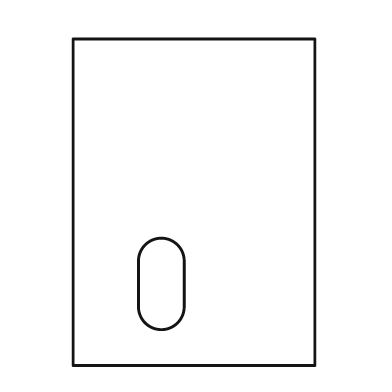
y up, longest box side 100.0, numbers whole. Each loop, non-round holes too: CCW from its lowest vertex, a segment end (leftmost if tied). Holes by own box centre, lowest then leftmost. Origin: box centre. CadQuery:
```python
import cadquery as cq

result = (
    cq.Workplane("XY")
    .moveTo(-37.0, -50.0)
    .lineTo(37.0, -50.0)
    .lineTo(37.0, 50.0)
    .lineTo(-37.0, 50.0)
    .close()
    .moveTo(-17.0, -32.0)
    .threePointArc((-10.0, -39.0), (-3.0, -32.0))
    .lineTo(-3.0, -18.0)
    .threePointArc((-10.0, -11.0), (-17.0, -18.0))
    .close()
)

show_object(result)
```